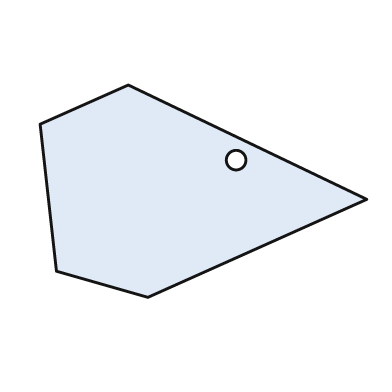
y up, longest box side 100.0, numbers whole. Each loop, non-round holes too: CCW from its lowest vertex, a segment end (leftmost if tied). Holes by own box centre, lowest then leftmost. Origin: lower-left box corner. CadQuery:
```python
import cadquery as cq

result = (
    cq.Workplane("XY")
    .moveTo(33.0, 0.0)
    .lineTo(100.0, 30.0)
    .lineTo(27.0, 65.0)
    .lineTo(0.0, 53.0)
    .lineTo(5.0, 8.0)
    .close()
    .moveTo(60.0, 42.0)
    .circle(3.0)
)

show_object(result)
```